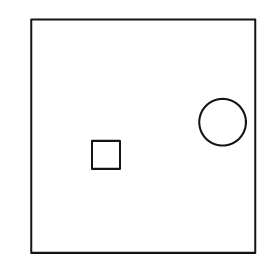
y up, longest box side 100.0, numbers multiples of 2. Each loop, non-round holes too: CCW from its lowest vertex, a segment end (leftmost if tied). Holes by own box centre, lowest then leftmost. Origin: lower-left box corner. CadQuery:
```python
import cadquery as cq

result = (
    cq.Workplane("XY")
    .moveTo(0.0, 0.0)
    .lineTo(96.0, 0.0)
    .lineTo(96.0, 100.0)
    .lineTo(0.0, 100.0)
    .close()
    .moveTo(26.0, 36.0)
    .lineTo(38.0, 36.0)
    .lineTo(38.0, 48.0)
    .lineTo(26.0, 48.0)
    .close()
    .moveTo(82.0, 56.0)
    .circle(10.0)
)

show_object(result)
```